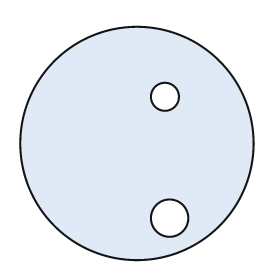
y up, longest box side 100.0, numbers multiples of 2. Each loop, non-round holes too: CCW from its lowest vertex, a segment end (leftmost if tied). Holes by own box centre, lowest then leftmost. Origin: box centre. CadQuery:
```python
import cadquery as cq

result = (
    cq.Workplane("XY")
    .moveTo(0.0, 0.0)
    .circle(50.0)
    .moveTo(14.0, -32.0)
    .circle(8.0)
    .moveTo(12.0, 20.0)
    .circle(6.0)
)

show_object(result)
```